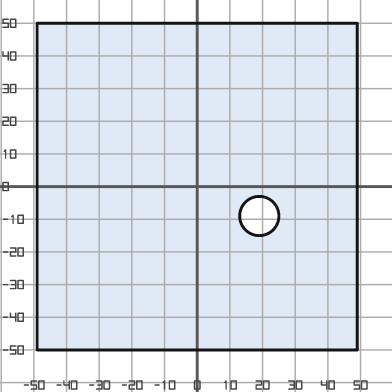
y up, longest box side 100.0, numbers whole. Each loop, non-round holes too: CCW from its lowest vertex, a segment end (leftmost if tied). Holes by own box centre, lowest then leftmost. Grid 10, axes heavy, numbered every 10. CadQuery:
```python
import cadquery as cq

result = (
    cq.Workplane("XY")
    .moveTo(-49.0, -50.0)
    .lineTo(49.0, -50.0)
    .lineTo(49.0, 50.0)
    .lineTo(-49.0, 50.0)
    .close()
    .moveTo(19.0, -9.0)
    .circle(6.0)
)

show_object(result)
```